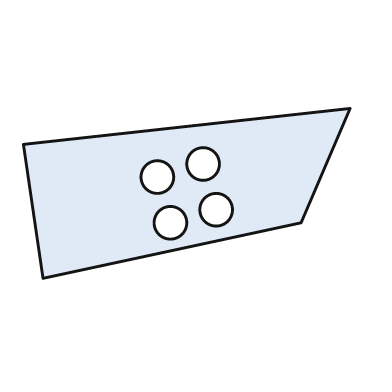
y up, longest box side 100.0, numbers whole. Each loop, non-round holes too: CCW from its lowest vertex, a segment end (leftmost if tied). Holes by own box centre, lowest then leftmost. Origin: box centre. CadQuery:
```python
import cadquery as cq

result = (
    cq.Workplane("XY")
    .moveTo(-44.0, -26.0)
    .lineTo(35.0, -9.0)
    .lineTo(50.0, 26.0)
    .lineTo(-50.0, 15.0)
    .close()
    .moveTo(-5.0, -9.0)
    .circle(5.0)
    .moveTo(9.0, -5.0)
    .circle(5.0)
    .moveTo(-9.0, 5.0)
    .circle(5.0)
    .moveTo(5.0, 9.0)
    .circle(5.0)
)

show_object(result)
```